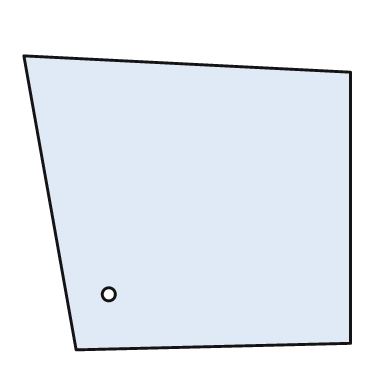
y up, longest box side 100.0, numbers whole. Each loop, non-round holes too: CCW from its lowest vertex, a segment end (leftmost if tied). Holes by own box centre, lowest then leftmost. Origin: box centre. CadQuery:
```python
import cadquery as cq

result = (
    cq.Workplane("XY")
    .moveTo(-34.0, -45.0)
    .lineTo(50.0, -43.0)
    .lineTo(50.0, 40.0)
    .lineTo(-50.0, 45.0)
    .close()
    .moveTo(-24.0, -28.0)
    .circle(2.0)
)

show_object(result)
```